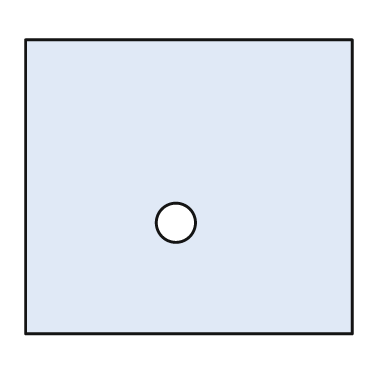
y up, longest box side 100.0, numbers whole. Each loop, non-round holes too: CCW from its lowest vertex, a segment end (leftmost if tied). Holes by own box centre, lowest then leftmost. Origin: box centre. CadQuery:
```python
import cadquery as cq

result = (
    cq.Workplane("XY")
    .moveTo(-50.0, -45.0)
    .lineTo(50.0, -45.0)
    .lineTo(50.0, 45.0)
    .lineTo(-50.0, 45.0)
    .close()
    .moveTo(-4.0, -11.0)
    .circle(6.0)
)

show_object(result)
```